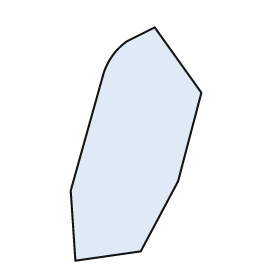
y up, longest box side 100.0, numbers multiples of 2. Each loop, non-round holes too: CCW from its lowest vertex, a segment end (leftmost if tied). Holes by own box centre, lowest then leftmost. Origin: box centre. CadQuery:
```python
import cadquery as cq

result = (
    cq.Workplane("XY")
    .moveTo(-26.0, -50.0)
    .lineTo(2.0, -46.0)
    .lineTo(18.0, -16.0)
    .lineTo(28.0, 22.0)
    .lineTo(8.0, 50.0)
    .lineTo(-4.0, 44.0)
    .threePointArc((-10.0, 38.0), (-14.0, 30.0))
    .lineTo(-28.0, -20.0)
    .close()
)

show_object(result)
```